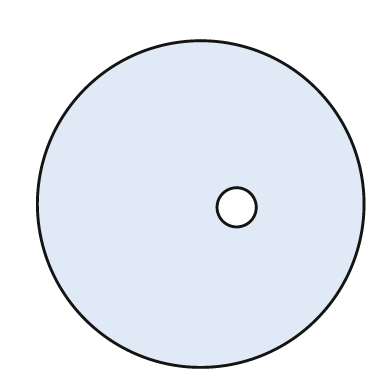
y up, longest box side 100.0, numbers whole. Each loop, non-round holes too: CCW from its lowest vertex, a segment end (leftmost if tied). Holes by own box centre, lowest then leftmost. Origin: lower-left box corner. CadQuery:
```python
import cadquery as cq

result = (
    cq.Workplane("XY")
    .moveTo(50.0, 50.0)
    .circle(50.0)
    .moveTo(61.0, 49.0)
    .circle(6.0)
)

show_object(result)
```